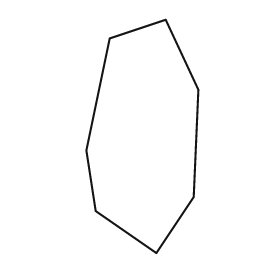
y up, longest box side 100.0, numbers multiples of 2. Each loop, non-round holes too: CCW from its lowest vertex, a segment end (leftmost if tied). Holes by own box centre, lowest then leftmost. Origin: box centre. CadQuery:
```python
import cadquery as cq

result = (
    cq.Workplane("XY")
    .moveTo(6.0, -50.0)
    .lineTo(22.0, -26.0)
    .lineTo(24.0, 20.0)
    .lineTo(10.0, 50.0)
    .lineTo(-14.0, 42.0)
    .lineTo(-24.0, -6.0)
    .lineTo(-20.0, -32.0)
    .close()
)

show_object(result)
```